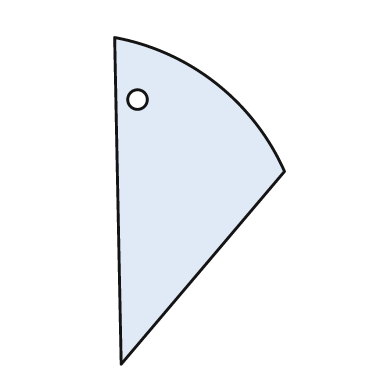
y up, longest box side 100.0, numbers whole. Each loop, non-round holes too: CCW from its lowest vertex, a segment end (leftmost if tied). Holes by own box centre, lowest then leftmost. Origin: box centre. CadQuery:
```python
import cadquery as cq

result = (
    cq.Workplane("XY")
    .moveTo(-24.0, -50.0)
    .lineTo(26.0, 9.0)
    .threePointArc((5.0, 36.0), (-26.0, 50.0))
    .close()
    .moveTo(-19.0, 31.0)
    .circle(3.0)
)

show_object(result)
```